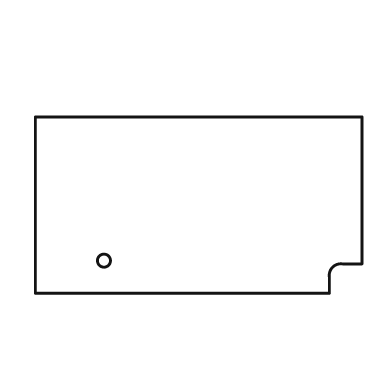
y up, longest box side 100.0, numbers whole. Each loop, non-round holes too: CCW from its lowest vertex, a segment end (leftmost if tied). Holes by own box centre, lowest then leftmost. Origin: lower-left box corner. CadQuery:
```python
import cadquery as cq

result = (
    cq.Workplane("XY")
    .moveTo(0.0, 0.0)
    .lineTo(90.0, 0.0)
    .lineTo(90.0, 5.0)
    .threePointArc((91.0, 8.0), (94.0, 9.0))
    .lineTo(100.0, 9.0)
    .lineTo(100.0, 54.0)
    .lineTo(0.0, 54.0)
    .close()
    .moveTo(21.0, 10.0)
    .circle(2.0)
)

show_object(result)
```